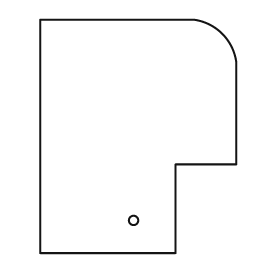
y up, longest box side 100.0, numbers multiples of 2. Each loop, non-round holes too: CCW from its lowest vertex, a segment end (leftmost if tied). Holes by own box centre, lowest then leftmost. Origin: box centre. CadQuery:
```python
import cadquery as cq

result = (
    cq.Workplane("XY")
    .moveTo(-42.0, -50.0)
    .lineTo(16.0, -50.0)
    .lineTo(16.0, -12.0)
    .lineTo(42.0, -12.0)
    .lineTo(42.0, 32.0)
    .threePointArc((36.0, 44.0), (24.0, 50.0))
    .lineTo(-42.0, 50.0)
    .close()
    .moveTo(-2.0, -36.0)
    .circle(2.0)
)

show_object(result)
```